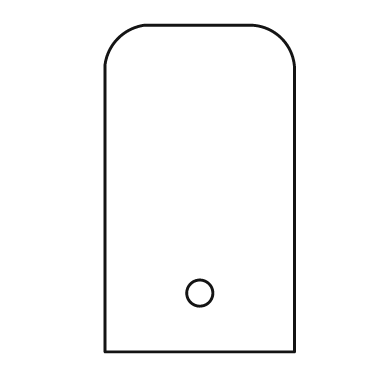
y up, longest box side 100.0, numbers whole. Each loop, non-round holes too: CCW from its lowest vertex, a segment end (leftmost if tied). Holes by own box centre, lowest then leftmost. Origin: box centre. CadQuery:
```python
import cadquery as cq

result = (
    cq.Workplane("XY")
    .moveTo(-29.0, -50.0)
    .lineTo(29.0, -50.0)
    .lineTo(29.0, 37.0)
    .threePointArc((25.0, 46.0), (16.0, 50.0))
    .lineTo(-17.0, 50.0)
    .threePointArc((-25.0, 46.0), (-29.0, 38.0))
    .close()
    .moveTo(0.0, -32.0)
    .circle(4.0)
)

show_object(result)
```